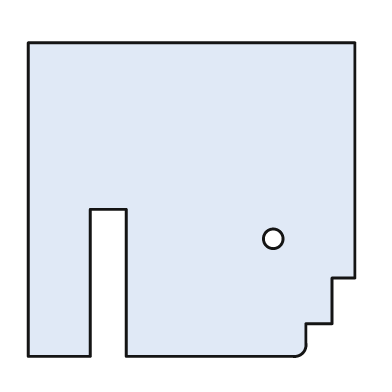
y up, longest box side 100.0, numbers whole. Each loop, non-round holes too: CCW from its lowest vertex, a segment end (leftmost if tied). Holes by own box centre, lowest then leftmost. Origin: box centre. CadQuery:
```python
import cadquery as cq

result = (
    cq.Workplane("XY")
    .moveTo(-50.0, -48.0)
    .lineTo(-31.0, -48.0)
    .lineTo(-31.0, -3.0)
    .lineTo(-20.0, -3.0)
    .lineTo(-20.0, -48.0)
    .lineTo(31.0, -48.0)
    .threePointArc((34.0, -47.0), (35.0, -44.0))
    .lineTo(35.0, -38.0)
    .lineTo(43.0, -38.0)
    .lineTo(43.0, -24.0)
    .lineTo(50.0, -24.0)
    .lineTo(50.0, 48.0)
    .lineTo(-50.0, 48.0)
    .close()
    .moveTo(25.0, -12.0)
    .circle(3.0)
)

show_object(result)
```